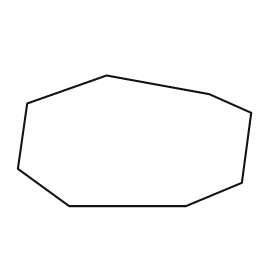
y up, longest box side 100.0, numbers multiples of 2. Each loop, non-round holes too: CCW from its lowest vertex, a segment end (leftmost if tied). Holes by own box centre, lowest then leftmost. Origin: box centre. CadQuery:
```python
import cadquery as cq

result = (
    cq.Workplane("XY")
    .moveTo(-28.0, -28.0)
    .lineTo(22.0, -28.0)
    .lineTo(46.0, -18.0)
    .lineTo(50.0, 12.0)
    .lineTo(32.0, 20.0)
    .lineTo(-12.0, 28.0)
    .lineTo(-46.0, 16.0)
    .lineTo(-50.0, -12.0)
    .close()
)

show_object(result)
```